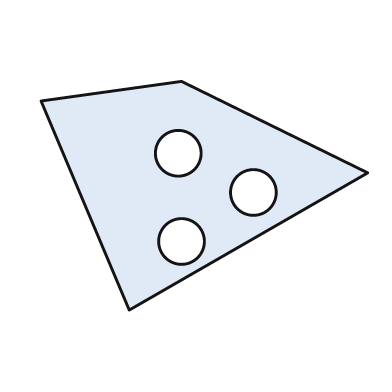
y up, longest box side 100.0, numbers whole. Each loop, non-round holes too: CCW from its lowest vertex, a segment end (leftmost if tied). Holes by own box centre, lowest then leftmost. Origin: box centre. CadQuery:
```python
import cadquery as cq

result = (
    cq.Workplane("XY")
    .moveTo(-23.0, -35.0)
    .lineTo(50.0, 7.0)
    .lineTo(-7.0, 35.0)
    .lineTo(-50.0, 29.0)
    .close()
    .moveTo(-7.0, -14.0)
    .circle(7.0)
    .moveTo(15.0, 1.0)
    .circle(7.0)
    .moveTo(-8.0, 13.0)
    .circle(7.0)
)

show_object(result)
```